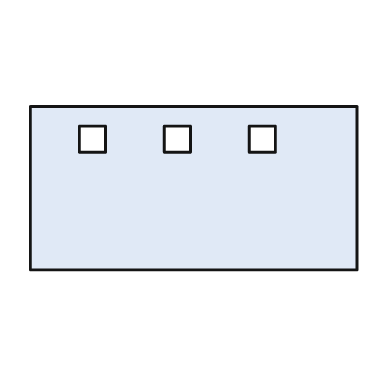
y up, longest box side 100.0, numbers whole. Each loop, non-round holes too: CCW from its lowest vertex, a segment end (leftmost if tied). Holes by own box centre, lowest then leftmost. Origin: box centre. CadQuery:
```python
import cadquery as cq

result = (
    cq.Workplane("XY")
    .moveTo(-50.0, -25.0)
    .lineTo(50.0, -25.0)
    .lineTo(50.0, 25.0)
    .lineTo(-50.0, 25.0)
    .close()
    .moveTo(-35.0, 11.0)
    .lineTo(-27.0, 11.0)
    .lineTo(-27.0, 19.0)
    .lineTo(-35.0, 19.0)
    .close()
    .moveTo(-9.0, 11.0)
    .lineTo(-1.0, 11.0)
    .lineTo(-1.0, 19.0)
    .lineTo(-9.0, 19.0)
    .close()
    .moveTo(17.0, 11.0)
    .lineTo(25.0, 11.0)
    .lineTo(25.0, 19.0)
    .lineTo(17.0, 19.0)
    .close()
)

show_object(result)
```